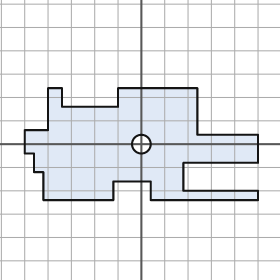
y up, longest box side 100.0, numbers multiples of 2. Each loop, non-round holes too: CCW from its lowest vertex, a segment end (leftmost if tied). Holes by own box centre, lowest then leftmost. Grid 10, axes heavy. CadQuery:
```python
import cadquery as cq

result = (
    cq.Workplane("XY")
    .moveTo(-42.0, -24.0)
    .lineTo(-12.0, -24.0)
    .lineTo(-12.0, -16.0)
    .lineTo(4.0, -16.0)
    .lineTo(4.0, -24.0)
    .lineTo(50.0, -24.0)
    .lineTo(50.0, -20.0)
    .lineTo(18.0, -20.0)
    .lineTo(18.0, -8.0)
    .lineTo(50.0, -8.0)
    .lineTo(50.0, 4.0)
    .lineTo(24.0, 4.0)
    .lineTo(24.0, 24.0)
    .lineTo(-10.0, 24.0)
    .lineTo(-10.0, 16.0)
    .lineTo(-34.0, 16.0)
    .lineTo(-34.0, 24.0)
    .lineTo(-40.0, 24.0)
    .lineTo(-40.0, 6.0)
    .lineTo(-50.0, 6.0)
    .lineTo(-50.0, -4.0)
    .lineTo(-46.0, -4.0)
    .lineTo(-46.0, -12.0)
    .lineTo(-42.0, -12.0)
    .close()
    .moveTo(0.0, 0.0)
    .circle(4.0)
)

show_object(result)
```